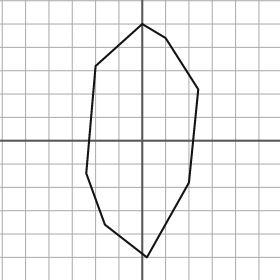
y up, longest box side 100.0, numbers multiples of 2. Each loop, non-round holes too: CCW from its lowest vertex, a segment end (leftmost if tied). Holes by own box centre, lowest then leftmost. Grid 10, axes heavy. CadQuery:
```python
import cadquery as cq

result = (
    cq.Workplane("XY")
    .moveTo(2.0, -50.0)
    .lineTo(20.0, -18.0)
    .lineTo(24.0, 22.0)
    .lineTo(10.0, 44.0)
    .lineTo(0.0, 50.0)
    .lineTo(-20.0, 32.0)
    .lineTo(-24.0, -14.0)
    .lineTo(-16.0, -36.0)
    .close()
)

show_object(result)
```